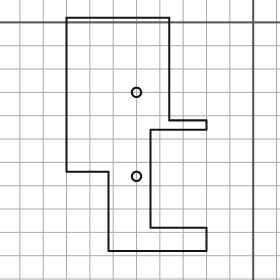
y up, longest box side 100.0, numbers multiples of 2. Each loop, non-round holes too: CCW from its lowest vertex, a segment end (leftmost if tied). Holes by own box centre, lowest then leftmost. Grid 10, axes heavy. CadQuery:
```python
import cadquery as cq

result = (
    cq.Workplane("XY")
    .moveTo(-62.0, -98.0)
    .lineTo(-20.0, -98.0)
    .lineTo(-20.0, -88.0)
    .lineTo(-44.0, -88.0)
    .lineTo(-44.0, -46.0)
    .lineTo(-20.0, -46.0)
    .lineTo(-20.0, -42.0)
    .lineTo(-36.0, -42.0)
    .lineTo(-36.0, 2.0)
    .lineTo(-80.0, 2.0)
    .lineTo(-80.0, -64.0)
    .lineTo(-62.0, -64.0)
    .close()
    .moveTo(-50.0, -66.0)
    .circle(2.0)
    .moveTo(-50.0, -30.0)
    .circle(2.0)
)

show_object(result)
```